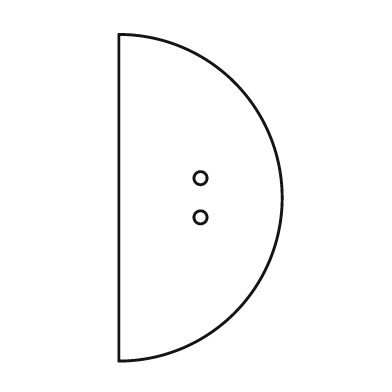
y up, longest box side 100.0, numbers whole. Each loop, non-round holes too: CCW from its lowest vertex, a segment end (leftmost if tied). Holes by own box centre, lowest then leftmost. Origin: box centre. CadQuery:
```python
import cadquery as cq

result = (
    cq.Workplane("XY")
    .moveTo(-25.0, -50.0)
    .threePointArc((25.0, 0.0), (-25.0, 50.0))
    .close()
    .moveTo(0.0, -6.0)
    .circle(2.0)
    .moveTo(0.0, 6.0)
    .circle(2.0)
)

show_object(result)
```